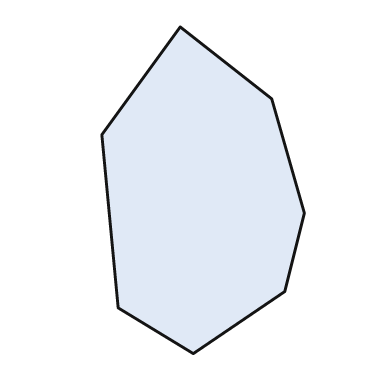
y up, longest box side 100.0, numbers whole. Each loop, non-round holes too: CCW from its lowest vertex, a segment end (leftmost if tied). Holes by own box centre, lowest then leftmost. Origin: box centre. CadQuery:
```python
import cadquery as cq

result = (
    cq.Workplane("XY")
    .moveTo(-3.0, -50.0)
    .lineTo(25.0, -31.0)
    .lineTo(31.0, -7.0)
    .lineTo(21.0, 28.0)
    .lineTo(-7.0, 50.0)
    .lineTo(-31.0, 17.0)
    .lineTo(-26.0, -36.0)
    .close()
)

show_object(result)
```